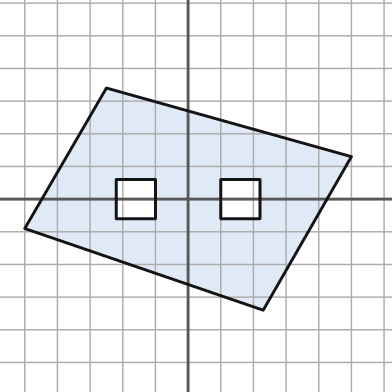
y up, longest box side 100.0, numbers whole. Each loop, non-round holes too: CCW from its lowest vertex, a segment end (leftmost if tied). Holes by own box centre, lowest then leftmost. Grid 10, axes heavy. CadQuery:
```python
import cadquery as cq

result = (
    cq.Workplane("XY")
    .moveTo(23.0, -34.0)
    .lineTo(50.0, 13.0)
    .lineTo(-25.0, 34.0)
    .lineTo(-50.0, -9.0)
    .close()
    .moveTo(-22.0, -6.0)
    .lineTo(-10.0, -6.0)
    .lineTo(-10.0, 6.0)
    .lineTo(-22.0, 6.0)
    .close()
    .moveTo(10.0, -6.0)
    .lineTo(22.0, -6.0)
    .lineTo(22.0, 6.0)
    .lineTo(10.0, 6.0)
    .close()
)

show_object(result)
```